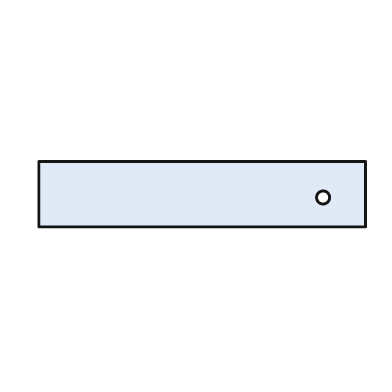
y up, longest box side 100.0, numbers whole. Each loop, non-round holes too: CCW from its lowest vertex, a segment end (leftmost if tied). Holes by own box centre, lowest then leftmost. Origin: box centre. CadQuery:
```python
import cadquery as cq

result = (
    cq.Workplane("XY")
    .moveTo(-50.0, -10.0)
    .lineTo(50.0, -10.0)
    .lineTo(50.0, 10.0)
    .lineTo(-50.0, 10.0)
    .close()
    .moveTo(37.0, -1.0)
    .circle(2.0)
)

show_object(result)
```